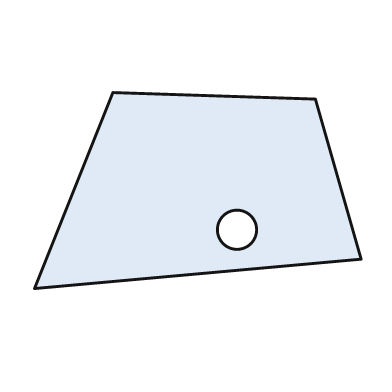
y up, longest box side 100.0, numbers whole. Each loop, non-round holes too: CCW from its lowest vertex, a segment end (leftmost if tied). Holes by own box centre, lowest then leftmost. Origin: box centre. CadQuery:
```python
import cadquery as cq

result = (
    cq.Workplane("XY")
    .moveTo(-50.0, -30.0)
    .lineTo(50.0, -21.0)
    .lineTo(36.0, 28.0)
    .lineTo(-26.0, 30.0)
    .close()
    .moveTo(12.0, -12.0)
    .circle(6.0)
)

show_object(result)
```